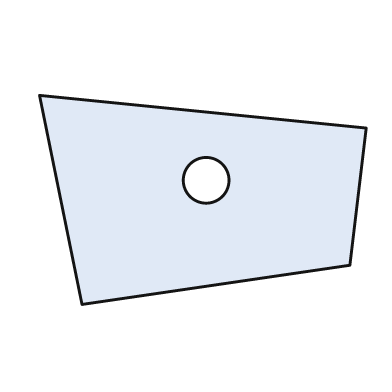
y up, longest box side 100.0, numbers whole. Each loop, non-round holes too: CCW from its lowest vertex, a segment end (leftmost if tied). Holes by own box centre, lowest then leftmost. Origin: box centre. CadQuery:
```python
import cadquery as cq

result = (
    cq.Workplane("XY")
    .moveTo(-37.0, -32.0)
    .lineTo(45.0, -20.0)
    .lineTo(50.0, 22.0)
    .lineTo(-50.0, 32.0)
    .close()
    .moveTo(1.0, 6.0)
    .circle(7.0)
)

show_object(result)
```